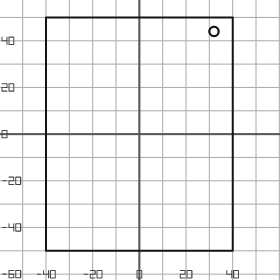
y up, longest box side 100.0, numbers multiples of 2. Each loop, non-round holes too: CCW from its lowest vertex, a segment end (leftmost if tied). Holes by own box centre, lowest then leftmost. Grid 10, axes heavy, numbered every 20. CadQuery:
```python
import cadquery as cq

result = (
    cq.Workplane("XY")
    .moveTo(-40.0, -50.0)
    .lineTo(40.0, -50.0)
    .lineTo(40.0, 50.0)
    .lineTo(-40.0, 50.0)
    .close()
    .moveTo(32.0, 44.0)
    .circle(2.0)
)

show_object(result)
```